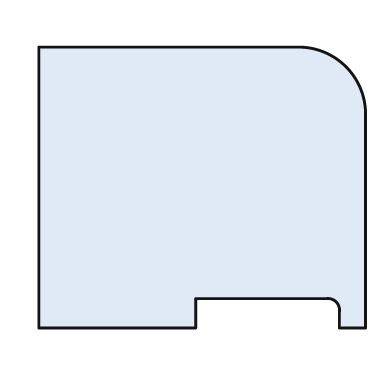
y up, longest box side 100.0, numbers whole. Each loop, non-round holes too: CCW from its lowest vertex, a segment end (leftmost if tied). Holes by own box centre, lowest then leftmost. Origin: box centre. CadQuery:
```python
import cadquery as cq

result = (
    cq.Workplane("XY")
    .moveTo(-50.0, -43.0)
    .lineTo(-2.0, -43.0)
    .lineTo(-2.0, -34.0)
    .lineTo(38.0, -34.0)
    .threePointArc((41.0, -35.0), (42.0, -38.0))
    .lineTo(42.0, -43.0)
    .lineTo(50.0, -43.0)
    .lineTo(50.0, 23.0)
    .threePointArc((44.0, 37.0), (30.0, 43.0))
    .lineTo(-50.0, 43.0)
    .close()
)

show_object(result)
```